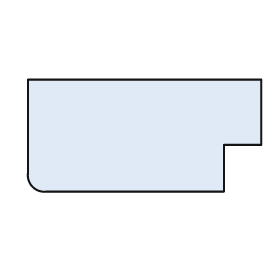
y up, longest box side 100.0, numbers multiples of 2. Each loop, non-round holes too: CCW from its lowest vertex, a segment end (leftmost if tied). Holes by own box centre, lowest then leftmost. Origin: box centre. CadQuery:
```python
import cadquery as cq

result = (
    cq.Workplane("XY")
    .moveTo(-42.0, -24.0)
    .lineTo(34.0, -24.0)
    .lineTo(34.0, -4.0)
    .lineTo(50.0, -4.0)
    .lineTo(50.0, 24.0)
    .lineTo(-50.0, 24.0)
    .lineTo(-50.0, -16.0)
    .threePointArc((-48.0, -22.0), (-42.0, -24.0))
    .close()
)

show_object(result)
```